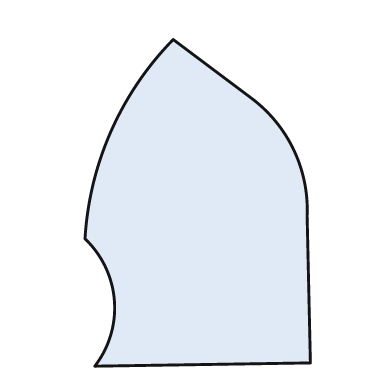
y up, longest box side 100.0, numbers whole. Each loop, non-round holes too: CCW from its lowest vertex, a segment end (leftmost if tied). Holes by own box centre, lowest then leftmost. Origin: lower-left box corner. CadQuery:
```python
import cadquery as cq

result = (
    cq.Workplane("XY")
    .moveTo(3.0, 0.0)
    .lineTo(69.0, 1.0)
    .lineTo(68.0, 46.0)
    .threePointArc((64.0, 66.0), (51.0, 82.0))
    .lineTo(27.0, 100.0)
    .threePointArc((8.0, 72.0), (0.0, 39.0))
    .threePointArc((9.0, 20.0), (3.0, 0.0))
    .close()
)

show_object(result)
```